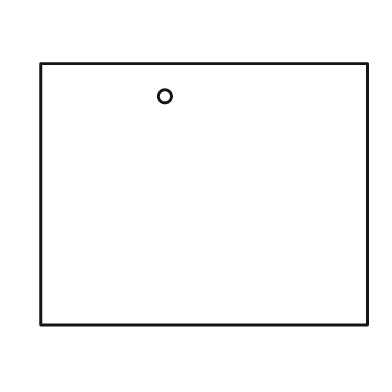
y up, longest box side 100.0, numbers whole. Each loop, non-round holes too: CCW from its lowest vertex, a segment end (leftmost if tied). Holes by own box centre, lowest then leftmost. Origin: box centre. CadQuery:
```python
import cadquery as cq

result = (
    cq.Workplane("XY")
    .moveTo(-50.0, -40.0)
    .lineTo(50.0, -40.0)
    .lineTo(50.0, 40.0)
    .lineTo(-50.0, 40.0)
    .close()
    .moveTo(-12.0, 30.0)
    .circle(2.0)
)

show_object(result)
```